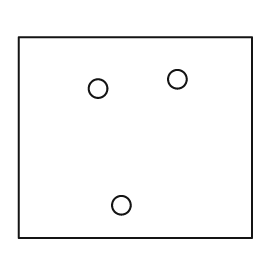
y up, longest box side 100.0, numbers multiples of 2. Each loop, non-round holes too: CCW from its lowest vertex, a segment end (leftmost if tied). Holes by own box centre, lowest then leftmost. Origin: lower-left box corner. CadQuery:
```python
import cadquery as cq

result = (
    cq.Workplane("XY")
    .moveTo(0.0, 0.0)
    .lineTo(100.0, 0.0)
    .lineTo(100.0, 86.0)
    .lineTo(0.0, 86.0)
    .close()
    .moveTo(44.0, 14.0)
    .circle(4.0)
    .moveTo(34.0, 64.0)
    .circle(4.0)
    .moveTo(68.0, 68.0)
    .circle(4.0)
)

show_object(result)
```